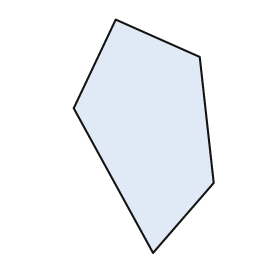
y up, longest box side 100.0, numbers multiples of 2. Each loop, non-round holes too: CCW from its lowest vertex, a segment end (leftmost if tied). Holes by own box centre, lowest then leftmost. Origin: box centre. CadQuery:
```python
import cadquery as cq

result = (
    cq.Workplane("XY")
    .moveTo(4.0, -50.0)
    .lineTo(30.0, -20.0)
    .lineTo(24.0, 34.0)
    .lineTo(-12.0, 50.0)
    .lineTo(-30.0, 12.0)
    .close()
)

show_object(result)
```